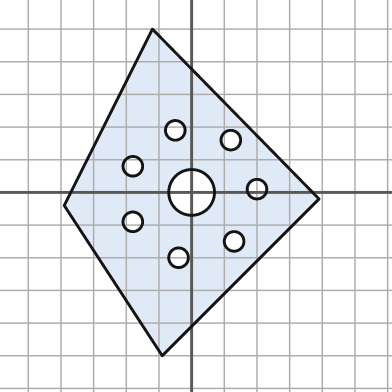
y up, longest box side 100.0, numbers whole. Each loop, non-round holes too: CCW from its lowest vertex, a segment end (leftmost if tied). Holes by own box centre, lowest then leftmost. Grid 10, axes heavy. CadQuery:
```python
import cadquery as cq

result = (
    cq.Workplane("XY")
    .moveTo(-9.0, -50.0)
    .lineTo(39.0, -2.0)
    .lineTo(-12.0, 50.0)
    .lineTo(-39.0, -4.0)
    .close()
    .moveTo(-4.0, -20.0)
    .circle(3.0)
    .moveTo(13.0, -15.0)
    .circle(3.0)
    .moveTo(-18.0, -9.0)
    .circle(3.0)
    .moveTo(0.0, 0.0)
    .circle(7.0)
    .moveTo(20.0, 1.0)
    .circle(3.0)
    .moveTo(-18.0, 8.0)
    .circle(3.0)
    .moveTo(12.0, 16.0)
    .circle(3.0)
    .moveTo(-5.0, 19.0)
    .circle(3.0)
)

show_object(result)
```